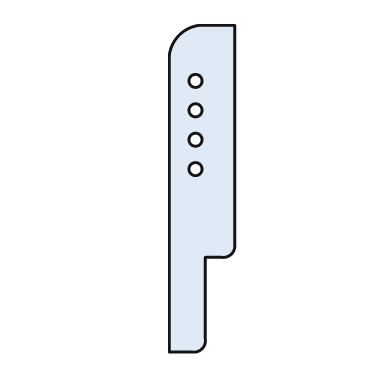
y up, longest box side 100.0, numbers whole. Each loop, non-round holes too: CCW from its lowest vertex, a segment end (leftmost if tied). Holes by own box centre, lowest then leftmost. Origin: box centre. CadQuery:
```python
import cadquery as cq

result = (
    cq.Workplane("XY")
    .moveTo(-10.0, -50.0)
    .lineTo(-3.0, -50.0)
    .threePointArc((0.0, -49.0), (1.0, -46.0))
    .lineTo(1.0, -21.0)
    .lineTo(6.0, -21.0)
    .threePointArc((9.0, -20.0), (10.0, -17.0))
    .lineTo(10.0, 50.0)
    .lineTo(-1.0, 50.0)
    .threePointArc((-7.0, 47.0), (-10.0, 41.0))
    .close()
    .moveTo(-2.0, 6.0)
    .circle(2.0)
    .moveTo(-2.0, 15.0)
    .circle(2.0)
    .moveTo(-2.0, 24.0)
    .circle(2.0)
    .moveTo(-2.0, 33.0)
    .circle(2.0)
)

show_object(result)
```